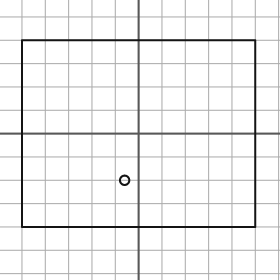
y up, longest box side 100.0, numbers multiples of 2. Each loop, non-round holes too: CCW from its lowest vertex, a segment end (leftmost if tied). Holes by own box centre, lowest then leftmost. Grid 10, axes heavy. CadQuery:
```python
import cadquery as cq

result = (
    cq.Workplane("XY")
    .moveTo(-50.0, -40.0)
    .lineTo(50.0, -40.0)
    .lineTo(50.0, 40.0)
    .lineTo(-50.0, 40.0)
    .close()
    .moveTo(-6.0, -20.0)
    .circle(2.0)
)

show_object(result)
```